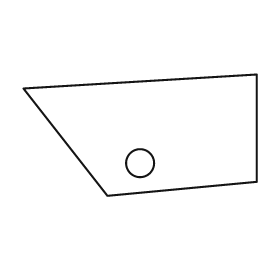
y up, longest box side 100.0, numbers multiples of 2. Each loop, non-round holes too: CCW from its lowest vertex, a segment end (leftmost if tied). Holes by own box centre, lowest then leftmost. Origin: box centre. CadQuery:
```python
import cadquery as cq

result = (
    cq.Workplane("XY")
    .moveTo(-14.0, -26.0)
    .lineTo(50.0, -20.0)
    .lineTo(50.0, 26.0)
    .lineTo(-50.0, 20.0)
    .close()
    .moveTo(0.0, -12.0)
    .circle(6.0)
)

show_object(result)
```